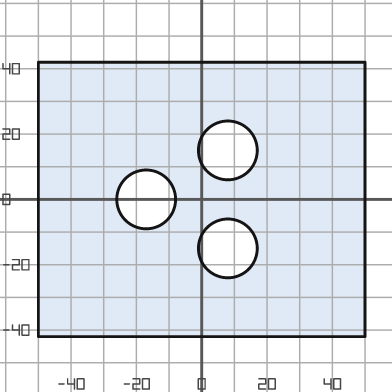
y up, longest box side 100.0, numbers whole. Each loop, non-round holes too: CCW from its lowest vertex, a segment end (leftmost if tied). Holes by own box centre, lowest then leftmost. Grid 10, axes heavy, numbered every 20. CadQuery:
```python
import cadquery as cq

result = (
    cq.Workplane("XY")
    .moveTo(-50.0, -42.0)
    .lineTo(50.0, -42.0)
    .lineTo(50.0, 42.0)
    .lineTo(-50.0, 42.0)
    .close()
    .moveTo(8.0, -15.0)
    .circle(9.0)
    .moveTo(-17.0, 0.0)
    .circle(9.0)
    .moveTo(8.0, 15.0)
    .circle(9.0)
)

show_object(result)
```